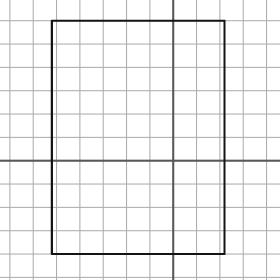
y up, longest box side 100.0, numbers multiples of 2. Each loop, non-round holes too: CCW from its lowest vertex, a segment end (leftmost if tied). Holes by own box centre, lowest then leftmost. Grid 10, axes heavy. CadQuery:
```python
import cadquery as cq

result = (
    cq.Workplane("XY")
    .moveTo(-52.0, -40.0)
    .lineTo(22.0, -40.0)
    .lineTo(22.0, 60.0)
    .lineTo(-52.0, 60.0)
    .close()
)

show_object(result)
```